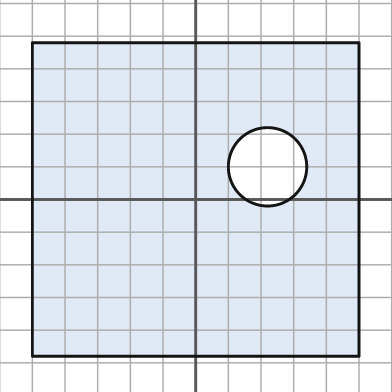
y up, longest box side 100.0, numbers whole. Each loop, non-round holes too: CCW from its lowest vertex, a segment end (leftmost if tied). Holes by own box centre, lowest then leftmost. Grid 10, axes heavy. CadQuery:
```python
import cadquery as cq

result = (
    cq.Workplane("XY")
    .moveTo(-50.0, -48.0)
    .lineTo(50.0, -48.0)
    .lineTo(50.0, 48.0)
    .lineTo(-50.0, 48.0)
    .close()
    .moveTo(22.0, 10.0)
    .circle(12.0)
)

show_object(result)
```